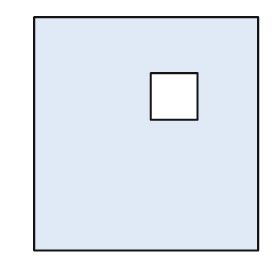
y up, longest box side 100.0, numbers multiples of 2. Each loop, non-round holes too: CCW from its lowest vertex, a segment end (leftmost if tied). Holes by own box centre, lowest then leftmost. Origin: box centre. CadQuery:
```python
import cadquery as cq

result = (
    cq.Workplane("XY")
    .moveTo(-48.0, -50.0)
    .lineTo(48.0, -50.0)
    .lineTo(48.0, 50.0)
    .lineTo(-48.0, 50.0)
    .close()
    .moveTo(2.0, 6.0)
    .lineTo(22.0, 6.0)
    .lineTo(22.0, 26.0)
    .lineTo(2.0, 26.0)
    .close()
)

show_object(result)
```